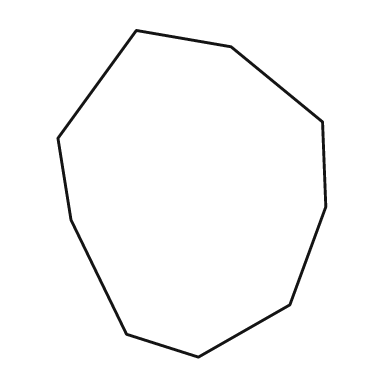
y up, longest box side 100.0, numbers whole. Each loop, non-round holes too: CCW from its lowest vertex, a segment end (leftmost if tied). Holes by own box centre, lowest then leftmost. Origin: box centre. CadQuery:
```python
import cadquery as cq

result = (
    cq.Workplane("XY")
    .moveTo(2.0, -50.0)
    .lineTo(30.0, -34.0)
    .lineTo(41.0, -4.0)
    .lineTo(40.0, 22.0)
    .lineTo(12.0, 45.0)
    .lineTo(-17.0, 50.0)
    .lineTo(-41.0, 17.0)
    .lineTo(-37.0, -8.0)
    .lineTo(-20.0, -43.0)
    .close()
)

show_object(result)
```